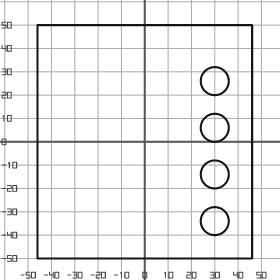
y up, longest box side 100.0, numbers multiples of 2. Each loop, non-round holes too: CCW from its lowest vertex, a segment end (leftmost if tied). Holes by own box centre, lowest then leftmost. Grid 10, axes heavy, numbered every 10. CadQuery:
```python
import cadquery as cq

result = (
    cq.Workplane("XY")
    .moveTo(-46.0, -50.0)
    .lineTo(46.0, -50.0)
    .lineTo(46.0, 50.0)
    .lineTo(-46.0, 50.0)
    .close()
    .moveTo(30.0, -34.0)
    .circle(6.0)
    .moveTo(30.0, -14.0)
    .circle(6.0)
    .moveTo(30.0, 6.0)
    .circle(6.0)
    .moveTo(30.0, 26.0)
    .circle(6.0)
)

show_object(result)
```